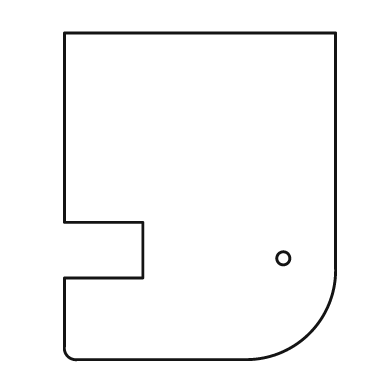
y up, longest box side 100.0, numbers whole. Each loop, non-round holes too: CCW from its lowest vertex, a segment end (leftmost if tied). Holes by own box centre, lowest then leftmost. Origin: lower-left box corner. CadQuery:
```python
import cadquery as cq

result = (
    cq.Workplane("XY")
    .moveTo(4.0, 0.0)
    .lineTo(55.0, 0.0)
    .threePointArc((75.0, 8.0), (83.0, 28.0))
    .lineTo(83.0, 100.0)
    .lineTo(0.0, 100.0)
    .lineTo(0.0, 42.0)
    .lineTo(24.0, 42.0)
    .lineTo(24.0, 25.0)
    .lineTo(0.0, 25.0)
    .lineTo(0.0, 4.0)
    .threePointArc((1.0, 1.0), (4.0, 0.0))
    .close()
    .moveTo(67.0, 31.0)
    .circle(2.0)
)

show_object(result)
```